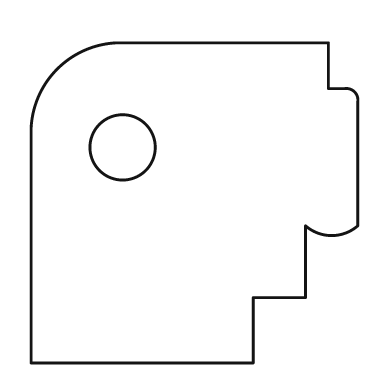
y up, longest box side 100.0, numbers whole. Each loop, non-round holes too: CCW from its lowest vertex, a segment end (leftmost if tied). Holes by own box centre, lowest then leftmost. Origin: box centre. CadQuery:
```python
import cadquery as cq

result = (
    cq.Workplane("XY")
    .moveTo(-50.0, -49.0)
    .lineTo(18.0, -49.0)
    .lineTo(18.0, -29.0)
    .lineTo(34.0, -29.0)
    .lineTo(34.0, -7.0)
    .threePointArc((42.0, -10.0), (50.0, -7.0))
    .lineTo(50.0, 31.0)
    .threePointArc((49.0, 34.0), (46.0, 35.0))
    .lineTo(41.0, 35.0)
    .lineTo(41.0, 49.0)
    .lineTo(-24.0, 49.0)
    .threePointArc((-42.0, 41.0), (-50.0, 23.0))
    .close()
    .moveTo(-22.0, 17.0)
    .circle(10.0)
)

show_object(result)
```